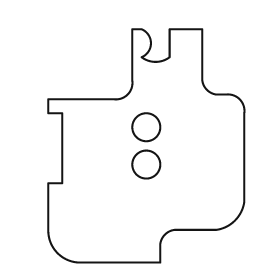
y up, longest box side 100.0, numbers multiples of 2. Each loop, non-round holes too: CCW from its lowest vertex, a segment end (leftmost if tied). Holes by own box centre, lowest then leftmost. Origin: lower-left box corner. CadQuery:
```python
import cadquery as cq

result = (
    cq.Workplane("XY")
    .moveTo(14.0, 0.0)
    .lineTo(48.0, 0.0)
    .lineTo(48.0, 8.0)
    .threePointArc((50.0, 12.0), (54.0, 14.0))
    .lineTo(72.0, 14.0)
    .threePointArc((80.0, 18.0), (84.0, 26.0))
    .lineTo(84.0, 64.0)
    .threePointArc((82.0, 70.0), (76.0, 72.0))
    .lineTo(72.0, 72.0)
    .threePointArc((68.0, 74.0), (66.0, 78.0))
    .lineTo(66.0, 100.0)
    .lineTo(52.0, 100.0)
    .lineTo(52.0, 88.0)
    .threePointArc((46.0, 86.0), (40.0, 88.0))
    .threePointArc((44.0, 94.0), (40.0, 100.0))
    .lineTo(36.0, 100.0)
    .lineTo(36.0, 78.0)
    .threePointArc((34.0, 72.0), (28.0, 70.0))
    .lineTo(0.0, 70.0)
    .lineTo(0.0, 64.0)
    .lineTo(6.0, 64.0)
    .lineTo(6.0, 34.0)
    .lineTo(0.0, 34.0)
    .lineTo(0.0, 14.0)
    .threePointArc((4.0, 4.0), (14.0, 0.0))
    .close()
    .moveTo(42.0, 42.0)
    .circle(6.0)
    .moveTo(42.0, 58.0)
    .circle(6.0)
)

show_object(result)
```